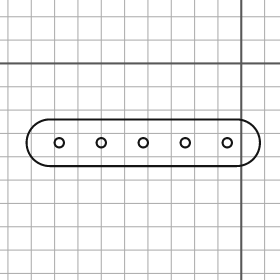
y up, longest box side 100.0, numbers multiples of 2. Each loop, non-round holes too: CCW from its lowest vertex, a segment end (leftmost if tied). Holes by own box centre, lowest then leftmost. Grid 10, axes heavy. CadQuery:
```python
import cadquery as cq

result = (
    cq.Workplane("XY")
    .moveTo(-82.0, -44.0)
    .lineTo(-2.0, -44.0)
    .threePointArc((8.0, -34.0), (-2.0, -24.0))
    .lineTo(-82.0, -24.0)
    .threePointArc((-92.0, -34.0), (-82.0, -44.0))
    .close()
    .moveTo(-78.0, -34.0)
    .circle(2.0)
    .moveTo(-60.0, -34.0)
    .circle(2.0)
    .moveTo(-42.0, -34.0)
    .circle(2.0)
    .moveTo(-24.0, -34.0)
    .circle(2.0)
    .moveTo(-6.0, -34.0)
    .circle(2.0)
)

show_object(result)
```